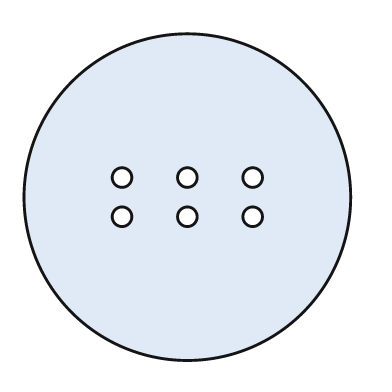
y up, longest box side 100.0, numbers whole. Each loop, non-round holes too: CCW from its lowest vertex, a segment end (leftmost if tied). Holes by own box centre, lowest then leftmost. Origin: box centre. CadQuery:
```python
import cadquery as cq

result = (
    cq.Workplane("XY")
    .moveTo(0.0, 0.0)
    .circle(50.0)
    .moveTo(-20.0, -6.0)
    .circle(3.0)
    .moveTo(0.0, -6.0)
    .circle(3.0)
    .moveTo(20.0, -6.0)
    .circle(3.0)
    .moveTo(-20.0, 6.0)
    .circle(3.0)
    .moveTo(0.0, 6.0)
    .circle(3.0)
    .moveTo(20.0, 6.0)
    .circle(3.0)
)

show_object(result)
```